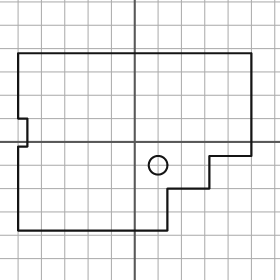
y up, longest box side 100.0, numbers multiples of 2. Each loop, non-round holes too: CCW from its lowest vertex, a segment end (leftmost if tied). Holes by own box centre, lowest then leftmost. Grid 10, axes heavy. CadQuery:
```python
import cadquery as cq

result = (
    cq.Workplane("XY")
    .moveTo(-50.0, -38.0)
    .lineTo(14.0, -38.0)
    .lineTo(14.0, -20.0)
    .lineTo(32.0, -20.0)
    .lineTo(32.0, -6.0)
    .lineTo(50.0, -6.0)
    .lineTo(50.0, 38.0)
    .lineTo(-50.0, 38.0)
    .lineTo(-50.0, 10.0)
    .lineTo(-46.0, 10.0)
    .lineTo(-46.0, -2.0)
    .lineTo(-50.0, -2.0)
    .close()
    .moveTo(10.0, -10.0)
    .circle(4.0)
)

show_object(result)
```